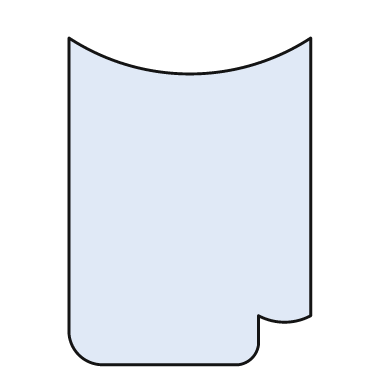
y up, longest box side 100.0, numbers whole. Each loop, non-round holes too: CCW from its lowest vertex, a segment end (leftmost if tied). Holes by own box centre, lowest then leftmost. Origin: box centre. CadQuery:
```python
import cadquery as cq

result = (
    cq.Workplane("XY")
    .moveTo(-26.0, -50.0)
    .lineTo(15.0, -50.0)
    .threePointArc((19.0, -48.0), (21.0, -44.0))
    .lineTo(21.0, -35.0)
    .threePointArc((29.0, -37.0), (37.0, -35.0))
    .lineTo(37.0, 50.0)
    .threePointArc((0.0, 39.0), (-37.0, 50.0))
    .lineTo(-37.0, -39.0)
    .threePointArc((-34.0, -47.0), (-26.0, -50.0))
    .close()
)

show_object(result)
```